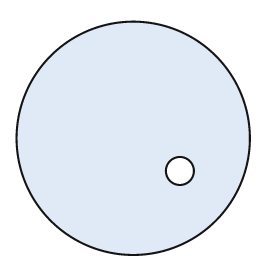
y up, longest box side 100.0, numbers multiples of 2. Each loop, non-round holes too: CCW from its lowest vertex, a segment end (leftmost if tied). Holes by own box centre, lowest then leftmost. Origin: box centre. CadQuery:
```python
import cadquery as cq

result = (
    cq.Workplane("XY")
    .moveTo(0.0, 0.0)
    .circle(50.0)
    .moveTo(20.0, -14.0)
    .circle(6.0)
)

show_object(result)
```